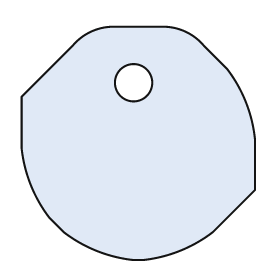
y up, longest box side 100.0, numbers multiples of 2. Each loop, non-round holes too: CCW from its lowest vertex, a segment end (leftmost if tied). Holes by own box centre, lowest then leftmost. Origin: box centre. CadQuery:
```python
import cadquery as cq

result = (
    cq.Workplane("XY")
    .moveTo(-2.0, -50.0)
    .lineTo(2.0, -50.0)
    .threePointArc((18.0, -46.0), (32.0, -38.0))
    .lineTo(50.0, -20.0)
    .lineTo(50.0, 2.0)
    .threePointArc((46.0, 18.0), (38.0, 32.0))
    .lineTo(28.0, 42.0)
    .threePointArc((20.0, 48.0), (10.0, 50.0))
    .lineTo(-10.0, 50.0)
    .threePointArc((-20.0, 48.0), (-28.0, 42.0))
    .lineTo(-50.0, 20.0)
    .lineTo(-50.0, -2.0)
    .threePointArc((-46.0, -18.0), (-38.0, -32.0))
    .lineTo(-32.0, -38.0)
    .threePointArc((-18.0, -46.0), (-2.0, -50.0))
    .close()
    .moveTo(-2.0, 26.0)
    .circle(8.0)
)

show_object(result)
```